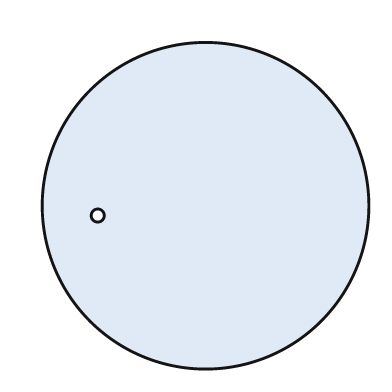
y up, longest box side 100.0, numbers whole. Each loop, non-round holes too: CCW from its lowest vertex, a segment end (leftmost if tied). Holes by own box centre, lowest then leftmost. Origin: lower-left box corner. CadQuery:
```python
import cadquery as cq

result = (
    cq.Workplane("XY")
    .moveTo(50.0, 50.0)
    .circle(50.0)
    .moveTo(17.0, 47.0)
    .circle(2.0)
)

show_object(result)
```